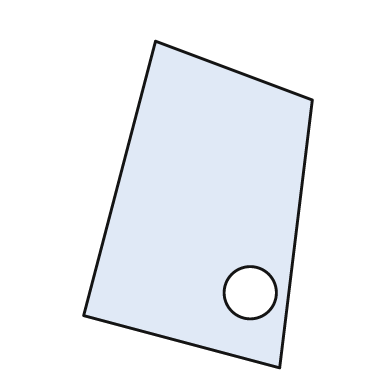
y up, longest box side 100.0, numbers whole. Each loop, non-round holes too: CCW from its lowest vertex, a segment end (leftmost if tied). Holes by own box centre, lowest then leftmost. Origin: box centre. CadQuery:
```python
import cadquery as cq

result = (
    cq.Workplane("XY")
    .moveTo(25.0, -50.0)
    .lineTo(35.0, 32.0)
    .lineTo(-13.0, 50.0)
    .lineTo(-35.0, -34.0)
    .close()
    .moveTo(16.0, -27.0)
    .circle(8.0)
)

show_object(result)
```